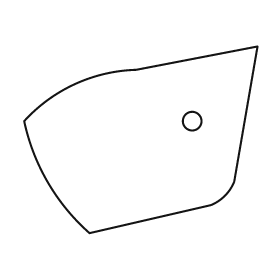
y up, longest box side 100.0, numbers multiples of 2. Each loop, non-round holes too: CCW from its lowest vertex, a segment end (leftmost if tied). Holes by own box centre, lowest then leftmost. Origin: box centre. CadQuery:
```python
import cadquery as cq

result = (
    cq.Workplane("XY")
    .moveTo(-22.0, -40.0)
    .lineTo(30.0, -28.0)
    .threePointArc((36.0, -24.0), (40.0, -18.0))
    .lineTo(50.0, 40.0)
    .lineTo(-2.0, 30.0)
    .threePointArc((-28.0, 24.0), (-50.0, 8.0))
    .threePointArc((-40.0, -18.0), (-22.0, -40.0))
    .close()
    .moveTo(22.0, 8.0)
    .circle(4.0)
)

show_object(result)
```